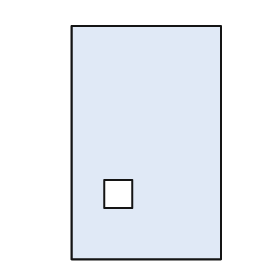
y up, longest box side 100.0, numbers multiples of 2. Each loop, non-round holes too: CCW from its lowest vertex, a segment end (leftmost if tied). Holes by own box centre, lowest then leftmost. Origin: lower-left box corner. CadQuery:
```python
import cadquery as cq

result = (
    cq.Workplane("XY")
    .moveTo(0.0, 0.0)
    .lineTo(64.0, 0.0)
    .lineTo(64.0, 100.0)
    .lineTo(0.0, 100.0)
    .close()
    .moveTo(14.0, 22.0)
    .lineTo(26.0, 22.0)
    .lineTo(26.0, 34.0)
    .lineTo(14.0, 34.0)
    .close()
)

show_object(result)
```